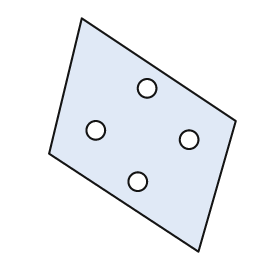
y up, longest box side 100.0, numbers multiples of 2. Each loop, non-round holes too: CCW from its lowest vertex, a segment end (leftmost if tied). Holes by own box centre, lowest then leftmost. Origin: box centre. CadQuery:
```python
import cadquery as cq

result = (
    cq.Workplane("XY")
    .moveTo(24.0, -50.0)
    .lineTo(40.0, 6.0)
    .lineTo(-26.0, 50.0)
    .lineTo(-40.0, -8.0)
    .close()
    .moveTo(-2.0, -20.0)
    .circle(4.0)
    .moveTo(20.0, -2.0)
    .circle(4.0)
    .moveTo(-20.0, 2.0)
    .circle(4.0)
    .moveTo(2.0, 20.0)
    .circle(4.0)
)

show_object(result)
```